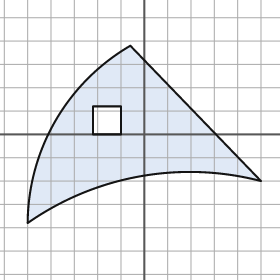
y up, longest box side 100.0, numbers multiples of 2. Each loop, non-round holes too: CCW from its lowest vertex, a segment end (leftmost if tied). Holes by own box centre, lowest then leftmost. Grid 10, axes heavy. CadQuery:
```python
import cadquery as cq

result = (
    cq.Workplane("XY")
    .moveTo(-50.0, -38.0)
    .threePointArc((-2.0, -18.0), (50.0, -20.0))
    .lineTo(-6.0, 38.0)
    .threePointArc((-38.0, 6.0), (-50.0, -38.0))
    .close()
    .moveTo(-22.0, 0.0)
    .lineTo(-10.0, 0.0)
    .lineTo(-10.0, 12.0)
    .lineTo(-22.0, 12.0)
    .close()
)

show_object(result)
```